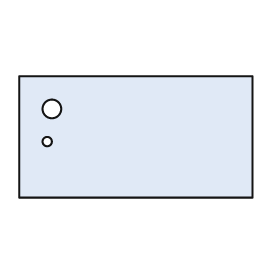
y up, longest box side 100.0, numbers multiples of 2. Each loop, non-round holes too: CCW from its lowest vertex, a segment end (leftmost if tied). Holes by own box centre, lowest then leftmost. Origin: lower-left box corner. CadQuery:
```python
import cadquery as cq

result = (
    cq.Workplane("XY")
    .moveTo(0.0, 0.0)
    .lineTo(100.0, 0.0)
    .lineTo(100.0, 52.0)
    .lineTo(0.0, 52.0)
    .close()
    .moveTo(12.0, 24.0)
    .circle(2.0)
    .moveTo(14.0, 38.0)
    .circle(4.0)
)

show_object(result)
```